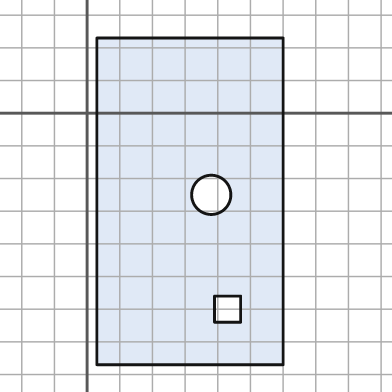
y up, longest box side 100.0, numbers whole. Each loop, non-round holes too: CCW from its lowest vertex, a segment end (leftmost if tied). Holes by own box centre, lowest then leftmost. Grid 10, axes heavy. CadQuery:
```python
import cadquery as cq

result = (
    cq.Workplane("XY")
    .moveTo(3.0, -77.0)
    .lineTo(60.0, -77.0)
    .lineTo(60.0, 23.0)
    .lineTo(3.0, 23.0)
    .close()
    .moveTo(39.0, -64.0)
    .lineTo(47.0, -64.0)
    .lineTo(47.0, -56.0)
    .lineTo(39.0, -56.0)
    .close()
    .moveTo(38.0, -25.0)
    .circle(6.0)
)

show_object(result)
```